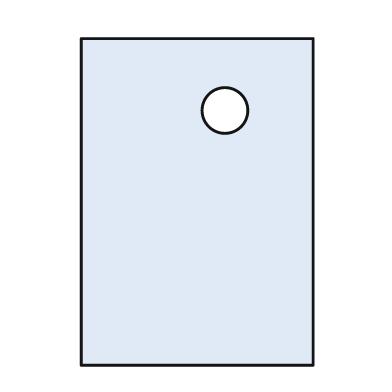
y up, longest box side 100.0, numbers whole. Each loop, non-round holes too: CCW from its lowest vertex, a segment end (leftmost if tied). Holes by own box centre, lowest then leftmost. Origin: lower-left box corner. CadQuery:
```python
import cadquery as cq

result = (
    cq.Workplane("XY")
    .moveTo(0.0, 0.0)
    .lineTo(71.0, 0.0)
    .lineTo(71.0, 100.0)
    .lineTo(0.0, 100.0)
    .close()
    .moveTo(44.0, 78.0)
    .circle(7.0)
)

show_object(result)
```